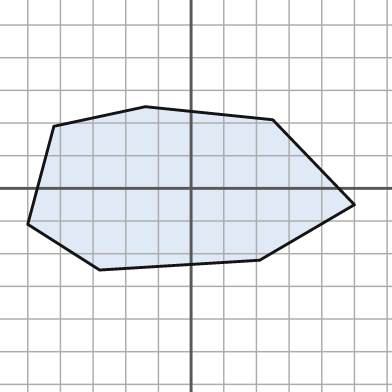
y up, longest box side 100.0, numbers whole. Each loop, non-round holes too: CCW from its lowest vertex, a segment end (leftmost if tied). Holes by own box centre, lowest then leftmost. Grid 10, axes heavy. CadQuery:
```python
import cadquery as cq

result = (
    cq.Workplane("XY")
    .moveTo(-28.0, -25.0)
    .lineTo(21.0, -22.0)
    .lineTo(50.0, -5.0)
    .lineTo(25.0, 21.0)
    .lineTo(-14.0, 25.0)
    .lineTo(-42.0, 19.0)
    .lineTo(-50.0, -11.0)
    .close()
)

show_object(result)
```